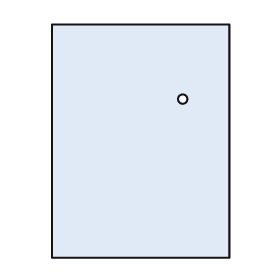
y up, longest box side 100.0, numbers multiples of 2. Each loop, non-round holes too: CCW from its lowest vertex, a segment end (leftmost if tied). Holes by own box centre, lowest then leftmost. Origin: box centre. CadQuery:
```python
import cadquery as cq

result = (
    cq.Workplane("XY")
    .moveTo(-38.0, -50.0)
    .lineTo(38.0, -50.0)
    .lineTo(38.0, 50.0)
    .lineTo(-38.0, 50.0)
    .close()
    .moveTo(18.0, 18.0)
    .circle(2.0)
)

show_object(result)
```